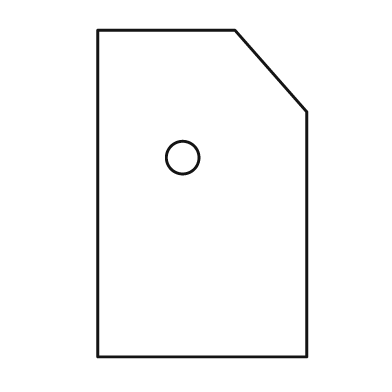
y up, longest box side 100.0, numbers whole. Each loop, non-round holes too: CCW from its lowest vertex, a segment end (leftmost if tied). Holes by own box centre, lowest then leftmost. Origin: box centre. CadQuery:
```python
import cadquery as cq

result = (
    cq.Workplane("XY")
    .moveTo(-32.0, -50.0)
    .lineTo(32.0, -50.0)
    .lineTo(32.0, 25.0)
    .lineTo(10.0, 50.0)
    .lineTo(-32.0, 50.0)
    .close()
    .moveTo(-6.0, 11.0)
    .circle(5.0)
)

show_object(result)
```